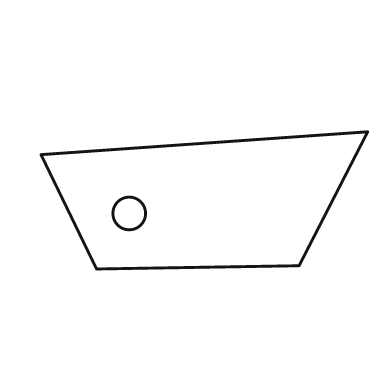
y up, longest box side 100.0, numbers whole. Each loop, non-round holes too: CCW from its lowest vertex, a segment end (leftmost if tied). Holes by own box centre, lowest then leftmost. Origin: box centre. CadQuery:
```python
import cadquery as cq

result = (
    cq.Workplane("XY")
    .moveTo(-33.0, -21.0)
    .lineTo(29.0, -20.0)
    .lineTo(50.0, 21.0)
    .lineTo(-50.0, 14.0)
    .close()
    .moveTo(-23.0, -4.0)
    .circle(5.0)
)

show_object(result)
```